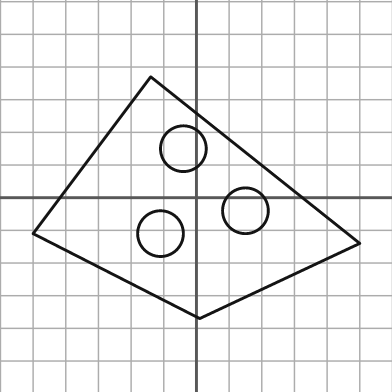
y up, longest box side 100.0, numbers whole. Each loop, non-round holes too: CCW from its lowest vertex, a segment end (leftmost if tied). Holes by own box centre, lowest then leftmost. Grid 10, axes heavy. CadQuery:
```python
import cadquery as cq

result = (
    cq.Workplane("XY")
    .moveTo(1.0, -37.0)
    .lineTo(50.0, -14.0)
    .lineTo(-14.0, 37.0)
    .lineTo(-50.0, -11.0)
    .close()
    .moveTo(-11.0, -11.0)
    .circle(7.0)
    .moveTo(15.0, -4.0)
    .circle(7.0)
    .moveTo(-4.0, 15.0)
    .circle(7.0)
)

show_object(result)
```